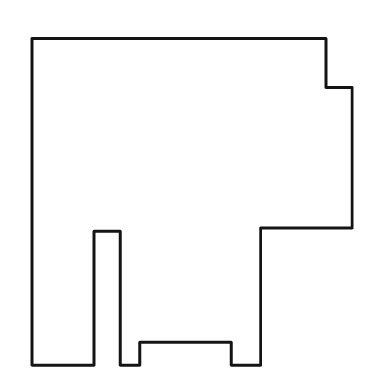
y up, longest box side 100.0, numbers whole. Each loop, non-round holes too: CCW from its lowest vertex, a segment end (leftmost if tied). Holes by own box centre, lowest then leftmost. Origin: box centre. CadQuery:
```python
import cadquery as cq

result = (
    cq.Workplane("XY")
    .moveTo(-49.0, -50.0)
    .lineTo(-30.0, -50.0)
    .lineTo(-30.0, -9.0)
    .lineTo(-22.0, -9.0)
    .lineTo(-22.0, -50.0)
    .lineTo(-16.0, -50.0)
    .lineTo(-16.0, -43.0)
    .lineTo(12.0, -43.0)
    .lineTo(12.0, -50.0)
    .lineTo(21.0, -50.0)
    .lineTo(21.0, -8.0)
    .lineTo(49.0, -8.0)
    .lineTo(49.0, 35.0)
    .lineTo(41.0, 35.0)
    .lineTo(41.0, 50.0)
    .lineTo(-49.0, 50.0)
    .close()
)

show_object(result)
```